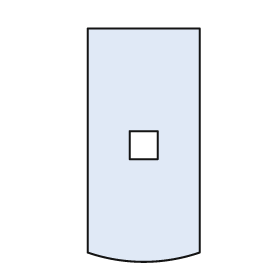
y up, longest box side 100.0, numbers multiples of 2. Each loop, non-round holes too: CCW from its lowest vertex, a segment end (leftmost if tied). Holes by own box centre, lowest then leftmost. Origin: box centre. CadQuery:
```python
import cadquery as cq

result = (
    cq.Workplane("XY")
    .moveTo(-24.0, -46.0)
    .threePointArc((0.0, -50.0), (24.0, -46.0))
    .lineTo(24.0, 50.0)
    .lineTo(-24.0, 50.0)
    .close()
    .moveTo(-6.0, -6.0)
    .lineTo(6.0, -6.0)
    .lineTo(6.0, 6.0)
    .lineTo(-6.0, 6.0)
    .close()
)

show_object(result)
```